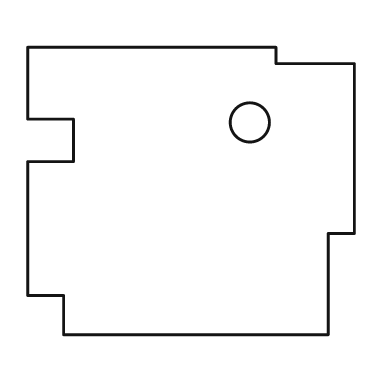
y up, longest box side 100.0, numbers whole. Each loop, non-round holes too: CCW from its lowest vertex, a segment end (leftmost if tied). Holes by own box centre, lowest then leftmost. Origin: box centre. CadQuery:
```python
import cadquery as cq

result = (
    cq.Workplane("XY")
    .moveTo(-39.0, -44.0)
    .lineTo(42.0, -44.0)
    .lineTo(42.0, -13.0)
    .lineTo(50.0, -13.0)
    .lineTo(50.0, 39.0)
    .lineTo(26.0, 39.0)
    .lineTo(26.0, 44.0)
    .lineTo(-50.0, 44.0)
    .lineTo(-50.0, 22.0)
    .lineTo(-36.0, 22.0)
    .lineTo(-36.0, 9.0)
    .lineTo(-50.0, 9.0)
    .lineTo(-50.0, -32.0)
    .lineTo(-39.0, -32.0)
    .close()
    .moveTo(18.0, 21.0)
    .circle(6.0)
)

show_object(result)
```